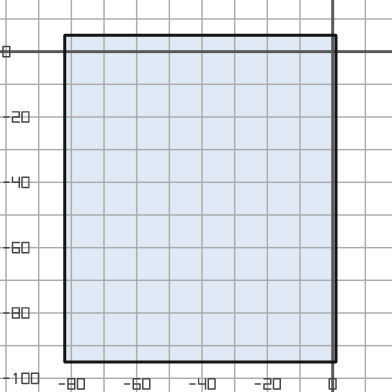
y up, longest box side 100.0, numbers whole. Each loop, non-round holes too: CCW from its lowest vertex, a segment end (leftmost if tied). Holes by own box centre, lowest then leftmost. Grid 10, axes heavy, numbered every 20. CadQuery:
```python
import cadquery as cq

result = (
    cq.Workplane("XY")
    .moveTo(-82.0, -95.0)
    .lineTo(1.0, -95.0)
    .lineTo(1.0, 5.0)
    .lineTo(-82.0, 5.0)
    .close()
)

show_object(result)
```